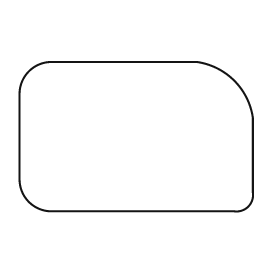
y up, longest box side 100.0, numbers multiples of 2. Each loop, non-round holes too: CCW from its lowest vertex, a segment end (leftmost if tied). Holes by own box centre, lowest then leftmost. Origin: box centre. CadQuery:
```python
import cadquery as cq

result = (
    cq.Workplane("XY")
    .moveTo(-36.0, -32.0)
    .lineTo(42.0, -32.0)
    .threePointArc((48.0, -30.0), (50.0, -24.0))
    .lineTo(50.0, 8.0)
    .threePointArc((42.0, 24.0), (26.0, 32.0))
    .lineTo(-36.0, 32.0)
    .threePointArc((-46.0, 28.0), (-50.0, 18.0))
    .lineTo(-50.0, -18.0)
    .threePointArc((-46.0, -28.0), (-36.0, -32.0))
    .close()
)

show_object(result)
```